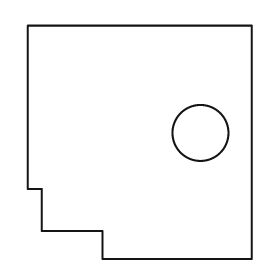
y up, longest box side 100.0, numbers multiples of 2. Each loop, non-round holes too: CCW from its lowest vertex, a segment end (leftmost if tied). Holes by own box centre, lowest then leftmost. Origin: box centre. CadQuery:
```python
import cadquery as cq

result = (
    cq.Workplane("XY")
    .moveTo(-16.0, -50.0)
    .lineTo(48.0, -50.0)
    .lineTo(48.0, 50.0)
    .lineTo(-48.0, 50.0)
    .lineTo(-48.0, -20.0)
    .lineTo(-42.0, -20.0)
    .lineTo(-42.0, -38.0)
    .lineTo(-16.0, -38.0)
    .close()
    .moveTo(26.0, 4.0)
    .circle(12.0)
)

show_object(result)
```